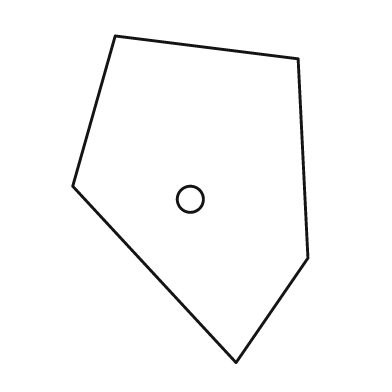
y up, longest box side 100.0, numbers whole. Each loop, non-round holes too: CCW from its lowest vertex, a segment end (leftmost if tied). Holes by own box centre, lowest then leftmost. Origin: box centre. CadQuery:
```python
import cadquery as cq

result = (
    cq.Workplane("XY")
    .moveTo(14.0, -50.0)
    .lineTo(36.0, -18.0)
    .lineTo(33.0, 43.0)
    .lineTo(-23.0, 50.0)
    .lineTo(-36.0, 4.0)
    .close()
    .moveTo(0.0, 0.0)
    .circle(4.0)
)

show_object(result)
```